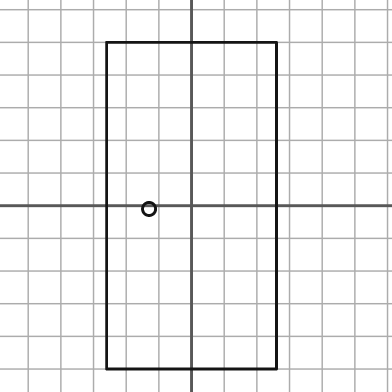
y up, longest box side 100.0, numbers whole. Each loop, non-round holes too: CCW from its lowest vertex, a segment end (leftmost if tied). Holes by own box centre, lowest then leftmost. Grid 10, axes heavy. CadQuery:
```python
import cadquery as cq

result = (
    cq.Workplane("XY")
    .moveTo(-26.0, -50.0)
    .lineTo(26.0, -50.0)
    .lineTo(26.0, 50.0)
    .lineTo(-26.0, 50.0)
    .close()
    .moveTo(-13.0, -1.0)
    .circle(2.0)
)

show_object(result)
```